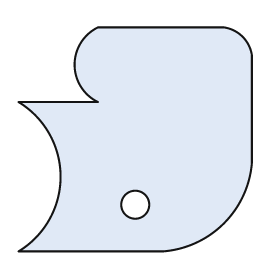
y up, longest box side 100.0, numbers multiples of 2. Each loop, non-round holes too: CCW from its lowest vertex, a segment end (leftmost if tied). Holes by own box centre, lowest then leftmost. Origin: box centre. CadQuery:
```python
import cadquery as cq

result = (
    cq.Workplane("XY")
    .moveTo(-50.0, -48.0)
    .lineTo(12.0, -48.0)
    .threePointArc((38.0, -36.0), (50.0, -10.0))
    .lineTo(50.0, 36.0)
    .threePointArc((46.0, 44.0), (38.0, 48.0))
    .lineTo(-16.0, 48.0)
    .threePointArc((-26.0, 32.0), (-16.0, 16.0))
    .lineTo(-50.0, 16.0)
    .threePointArc((-32.0, -16.0), (-50.0, -48.0))
    .close()
    .moveTo(0.0, -28.0)
    .circle(6.0)
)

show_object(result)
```